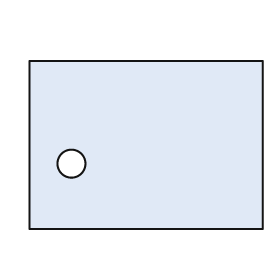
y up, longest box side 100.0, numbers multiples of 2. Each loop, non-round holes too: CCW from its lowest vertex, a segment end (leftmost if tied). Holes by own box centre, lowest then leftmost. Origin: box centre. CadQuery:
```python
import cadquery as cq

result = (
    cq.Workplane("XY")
    .moveTo(-50.0, -36.0)
    .lineTo(50.0, -36.0)
    .lineTo(50.0, 36.0)
    .lineTo(-50.0, 36.0)
    .close()
    .moveTo(-32.0, -8.0)
    .circle(6.0)
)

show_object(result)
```